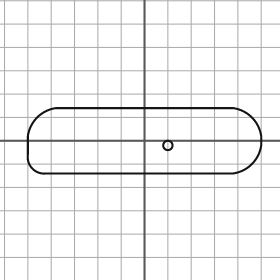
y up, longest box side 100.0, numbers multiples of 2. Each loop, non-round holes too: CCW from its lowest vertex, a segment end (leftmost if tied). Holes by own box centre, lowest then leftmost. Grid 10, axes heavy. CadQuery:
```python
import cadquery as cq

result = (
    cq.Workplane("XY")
    .moveTo(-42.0, -14.0)
    .lineTo(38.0, -14.0)
    .threePointArc((46.0, -10.0), (50.0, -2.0))
    .lineTo(50.0, 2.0)
    .threePointArc((46.0, 10.0), (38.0, 14.0))
    .lineTo(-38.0, 14.0)
    .threePointArc((-46.0, 10.0), (-50.0, 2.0))
    .lineTo(-50.0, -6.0)
    .threePointArc((-48.0, -12.0), (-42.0, -14.0))
    .close()
    .moveTo(10.0, -2.0)
    .circle(2.0)
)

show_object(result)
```